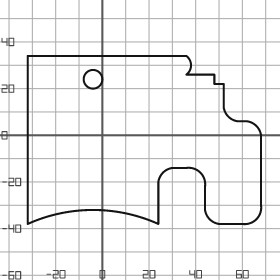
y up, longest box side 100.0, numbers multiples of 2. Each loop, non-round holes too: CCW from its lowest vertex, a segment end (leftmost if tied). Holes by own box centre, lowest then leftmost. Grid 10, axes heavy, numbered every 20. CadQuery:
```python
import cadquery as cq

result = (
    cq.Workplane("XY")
    .moveTo(-32.0, -38.0)
    .threePointArc((-4.0, -32.0), (24.0, -38.0))
    .lineTo(24.0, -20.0)
    .threePointArc((26.0, -16.0), (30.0, -14.0))
    .lineTo(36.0, -14.0)
    .threePointArc((42.0, -16.0), (44.0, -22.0))
    .lineTo(44.0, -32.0)
    .threePointArc((46.0, -36.0), (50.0, -38.0))
    .lineTo(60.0, -38.0)
    .threePointArc((66.0, -36.0), (68.0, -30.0))
    .lineTo(68.0, 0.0)
    .threePointArc((66.0, 4.0), (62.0, 6.0))
    .lineTo(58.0, 6.0)
    .threePointArc((54.0, 8.0), (52.0, 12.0))
    .lineTo(52.0, 22.0)
    .lineTo(48.0, 22.0)
    .lineTo(48.0, 26.0)
    .lineTo(36.0, 26.0)
    .threePointArc((38.0, 30.0), (36.0, 34.0))
    .lineTo(-32.0, 34.0)
    .close()
    .moveTo(-4.0, 24.0)
    .circle(4.0)
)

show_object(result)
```